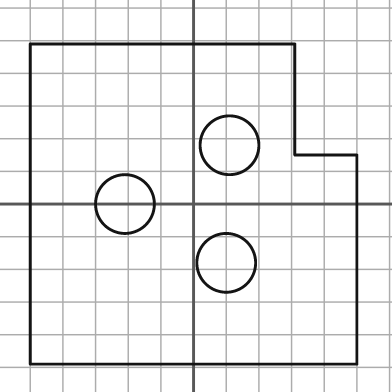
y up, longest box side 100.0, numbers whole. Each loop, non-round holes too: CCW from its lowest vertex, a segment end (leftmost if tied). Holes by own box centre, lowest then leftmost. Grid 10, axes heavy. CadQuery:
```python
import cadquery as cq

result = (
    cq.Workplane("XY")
    .moveTo(-50.0, -49.0)
    .lineTo(50.0, -49.0)
    .lineTo(50.0, 15.0)
    .lineTo(31.0, 15.0)
    .lineTo(31.0, 49.0)
    .lineTo(-50.0, 49.0)
    .close()
    .moveTo(10.0, -18.0)
    .circle(9.0)
    .moveTo(-21.0, 0.0)
    .circle(9.0)
    .moveTo(11.0, 18.0)
    .circle(9.0)
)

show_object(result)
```